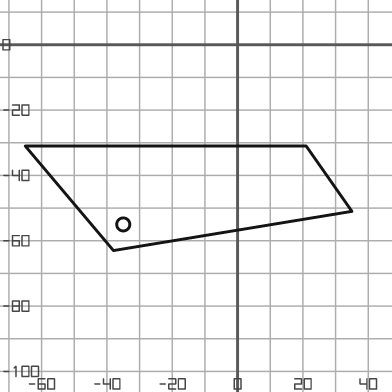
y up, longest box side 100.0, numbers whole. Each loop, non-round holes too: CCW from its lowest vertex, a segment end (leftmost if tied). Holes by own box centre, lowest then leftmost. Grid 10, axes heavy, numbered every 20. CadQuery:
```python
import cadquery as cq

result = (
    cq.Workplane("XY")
    .moveTo(-38.0, -63.0)
    .lineTo(35.0, -51.0)
    .lineTo(21.0, -31.0)
    .lineTo(-65.0, -31.0)
    .close()
    .moveTo(-35.0, -55.0)
    .circle(2.0)
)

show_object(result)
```